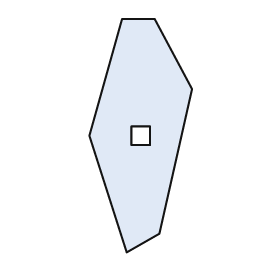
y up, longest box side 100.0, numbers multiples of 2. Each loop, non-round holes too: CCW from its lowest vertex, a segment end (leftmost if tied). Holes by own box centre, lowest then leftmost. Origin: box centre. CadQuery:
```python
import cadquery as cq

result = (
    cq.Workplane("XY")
    .moveTo(-6.0, -50.0)
    .lineTo(8.0, -42.0)
    .lineTo(22.0, 20.0)
    .lineTo(6.0, 50.0)
    .lineTo(-8.0, 50.0)
    .lineTo(-22.0, 0.0)
    .close()
    .moveTo(-4.0, -4.0)
    .lineTo(4.0, -4.0)
    .lineTo(4.0, 4.0)
    .lineTo(-4.0, 4.0)
    .close()
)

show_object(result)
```